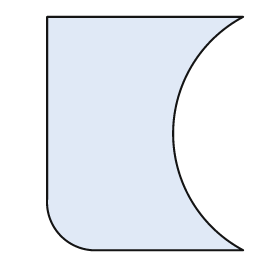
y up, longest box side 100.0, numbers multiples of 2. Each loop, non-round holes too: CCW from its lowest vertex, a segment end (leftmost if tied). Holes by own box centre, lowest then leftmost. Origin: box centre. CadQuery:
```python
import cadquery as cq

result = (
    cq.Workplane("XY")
    .moveTo(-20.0, -50.0)
    .lineTo(42.0, -50.0)
    .threePointArc((12.0, 0.0), (42.0, 50.0))
    .lineTo(-42.0, 50.0)
    .lineTo(-42.0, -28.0)
    .threePointArc((-36.0, -44.0), (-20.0, -50.0))
    .close()
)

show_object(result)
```